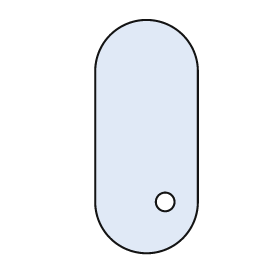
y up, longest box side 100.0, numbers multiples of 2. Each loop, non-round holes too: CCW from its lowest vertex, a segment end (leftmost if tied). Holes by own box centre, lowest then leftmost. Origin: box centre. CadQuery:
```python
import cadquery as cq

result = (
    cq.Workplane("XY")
    .moveTo(-22.0, -28.0)
    .threePointArc((0.0, -50.0), (22.0, -28.0))
    .lineTo(22.0, 28.0)
    .threePointArc((0.0, 50.0), (-22.0, 28.0))
    .close()
    .moveTo(8.0, -28.0)
    .circle(4.0)
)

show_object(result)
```